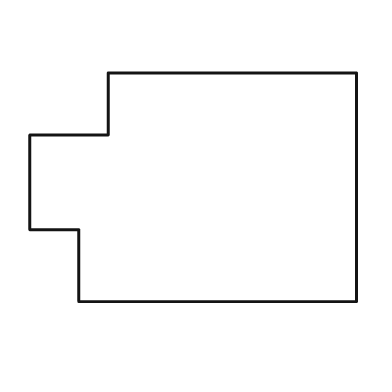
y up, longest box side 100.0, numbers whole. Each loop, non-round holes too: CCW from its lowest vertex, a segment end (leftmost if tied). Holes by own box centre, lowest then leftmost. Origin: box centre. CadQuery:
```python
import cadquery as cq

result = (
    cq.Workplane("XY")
    .moveTo(-35.0, -35.0)
    .lineTo(50.0, -35.0)
    .lineTo(50.0, 35.0)
    .lineTo(-26.0, 35.0)
    .lineTo(-26.0, 16.0)
    .lineTo(-50.0, 16.0)
    .lineTo(-50.0, -13.0)
    .lineTo(-35.0, -13.0)
    .close()
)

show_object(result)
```